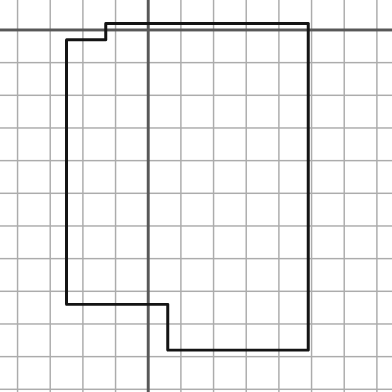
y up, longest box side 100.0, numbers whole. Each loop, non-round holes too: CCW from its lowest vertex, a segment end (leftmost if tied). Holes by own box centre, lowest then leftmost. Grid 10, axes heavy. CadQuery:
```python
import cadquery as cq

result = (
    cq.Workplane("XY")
    .moveTo(6.0, -98.0)
    .lineTo(49.0, -98.0)
    .lineTo(49.0, 2.0)
    .lineTo(-13.0, 2.0)
    .lineTo(-13.0, -3.0)
    .lineTo(-25.0, -3.0)
    .lineTo(-25.0, -84.0)
    .lineTo(6.0, -84.0)
    .close()
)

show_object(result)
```